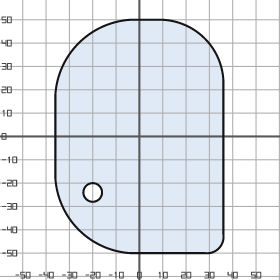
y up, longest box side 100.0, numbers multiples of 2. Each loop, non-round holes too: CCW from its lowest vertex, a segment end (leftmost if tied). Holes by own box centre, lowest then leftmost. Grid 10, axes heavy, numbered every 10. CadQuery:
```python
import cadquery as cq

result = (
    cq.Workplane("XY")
    .moveTo(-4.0, -50.0)
    .lineTo(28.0, -50.0)
    .threePointArc((34.0, -48.0), (36.0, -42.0))
    .lineTo(36.0, 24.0)
    .threePointArc((28.0, 42.0), (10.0, 50.0))
    .lineTo(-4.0, 50.0)
    .threePointArc((-26.0, 40.0), (-36.0, 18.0))
    .lineTo(-36.0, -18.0)
    .threePointArc((-26.0, -40.0), (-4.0, -50.0))
    .close()
    .moveTo(-20.0, -24.0)
    .circle(4.0)
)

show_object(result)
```